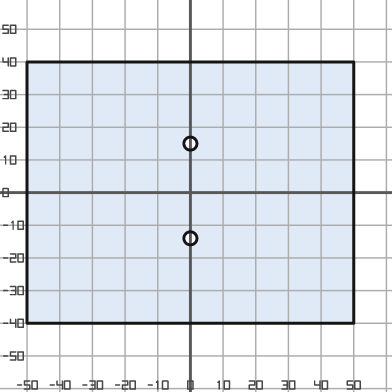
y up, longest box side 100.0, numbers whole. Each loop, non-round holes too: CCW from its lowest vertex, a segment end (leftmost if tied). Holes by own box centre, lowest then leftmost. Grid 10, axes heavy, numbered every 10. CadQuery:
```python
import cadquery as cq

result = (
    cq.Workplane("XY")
    .moveTo(-50.0, -40.0)
    .lineTo(50.0, -40.0)
    .lineTo(50.0, 40.0)
    .lineTo(-50.0, 40.0)
    .close()
    .moveTo(0.0, -14.0)
    .circle(2.0)
    .moveTo(0.0, 15.0)
    .circle(2.0)
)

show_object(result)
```